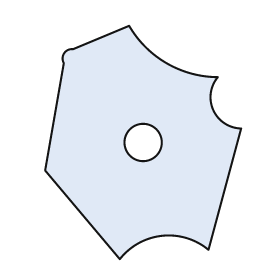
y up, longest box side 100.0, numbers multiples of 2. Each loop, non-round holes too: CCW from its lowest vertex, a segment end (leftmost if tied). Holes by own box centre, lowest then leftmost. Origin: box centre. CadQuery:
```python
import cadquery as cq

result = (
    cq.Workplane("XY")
    .moveTo(-10.0, -50.0)
    .threePointArc((8.0, -40.0), (28.0, -46.0))
    .lineTo(42.0, 6.0)
    .threePointArc((30.0, 14.0), (32.0, 28.0))
    .threePointArc((10.0, 34.0), (-6.0, 50.0))
    .lineTo(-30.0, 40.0)
    .threePointArc((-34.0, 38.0), (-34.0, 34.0))
    .lineTo(-42.0, -12.0)
    .close()
    .moveTo(0.0, 0.0)
    .circle(8.0)
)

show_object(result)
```